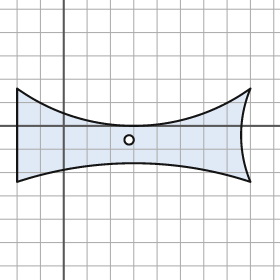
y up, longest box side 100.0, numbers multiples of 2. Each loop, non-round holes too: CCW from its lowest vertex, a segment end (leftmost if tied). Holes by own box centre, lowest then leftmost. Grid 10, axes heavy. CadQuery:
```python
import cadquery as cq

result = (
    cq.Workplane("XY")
    .moveTo(-20.0, -24.0)
    .threePointArc((30.0, -16.0), (80.0, -24.0))
    .threePointArc((76.0, -4.0), (80.0, 16.0))
    .threePointArc((30.0, 0.0), (-20.0, 16.0))
    .close()
    .moveTo(28.0, -6.0)
    .circle(2.0)
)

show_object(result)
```